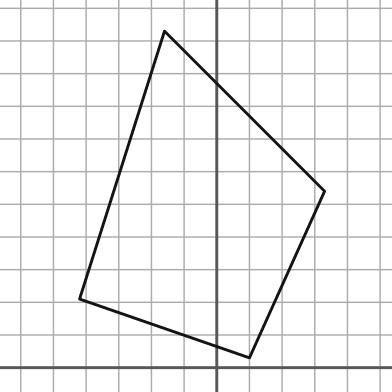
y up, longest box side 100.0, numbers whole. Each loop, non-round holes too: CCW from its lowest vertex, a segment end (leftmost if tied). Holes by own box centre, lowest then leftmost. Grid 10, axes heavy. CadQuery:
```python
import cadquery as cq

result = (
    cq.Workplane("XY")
    .moveTo(10.0, 3.0)
    .lineTo(33.0, 54.0)
    .lineTo(-16.0, 103.0)
    .lineTo(-42.0, 21.0)
    .close()
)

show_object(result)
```